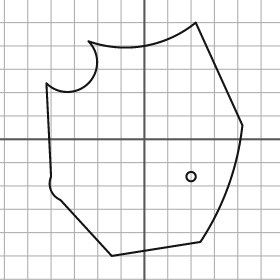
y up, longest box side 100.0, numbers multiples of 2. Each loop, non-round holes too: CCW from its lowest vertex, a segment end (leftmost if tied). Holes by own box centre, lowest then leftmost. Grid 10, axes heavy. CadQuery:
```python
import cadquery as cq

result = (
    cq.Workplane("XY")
    .moveTo(-14.0, -50.0)
    .lineTo(24.0, -44.0)
    .threePointArc((36.0, -20.0), (42.0, 6.0))
    .lineTo(22.0, 50.0)
    .threePointArc((0.0, 40.0), (-24.0, 42.0))
    .threePointArc((-24.0, 24.0), (-42.0, 24.0))
    .lineTo(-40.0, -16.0)
    .threePointArc((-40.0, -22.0), (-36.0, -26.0))
    .close()
    .moveTo(20.0, -16.0)
    .circle(2.0)
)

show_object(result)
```